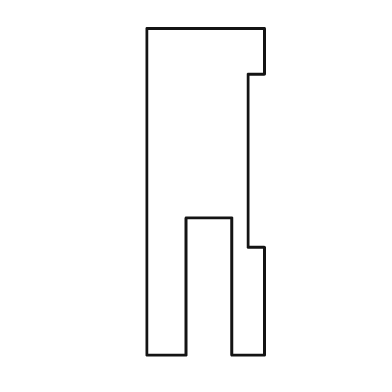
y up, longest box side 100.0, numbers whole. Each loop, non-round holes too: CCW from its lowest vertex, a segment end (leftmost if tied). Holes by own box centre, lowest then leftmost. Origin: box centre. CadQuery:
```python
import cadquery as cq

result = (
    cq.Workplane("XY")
    .moveTo(-18.0, -50.0)
    .lineTo(-6.0, -50.0)
    .lineTo(-6.0, -8.0)
    .lineTo(8.0, -8.0)
    .lineTo(8.0, -50.0)
    .lineTo(18.0, -50.0)
    .lineTo(18.0, -17.0)
    .lineTo(13.0, -17.0)
    .lineTo(13.0, 36.0)
    .lineTo(18.0, 36.0)
    .lineTo(18.0, 50.0)
    .lineTo(-18.0, 50.0)
    .close()
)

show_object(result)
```